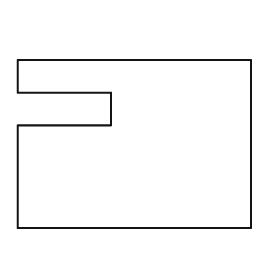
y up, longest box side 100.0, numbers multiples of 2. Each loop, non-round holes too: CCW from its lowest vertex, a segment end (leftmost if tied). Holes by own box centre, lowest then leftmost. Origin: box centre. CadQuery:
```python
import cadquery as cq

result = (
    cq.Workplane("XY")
    .moveTo(-50.0, -36.0)
    .lineTo(50.0, -36.0)
    .lineTo(50.0, 36.0)
    .lineTo(-50.0, 36.0)
    .lineTo(-50.0, 22.0)
    .lineTo(-10.0, 22.0)
    .lineTo(-10.0, 8.0)
    .lineTo(-50.0, 8.0)
    .close()
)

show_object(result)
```